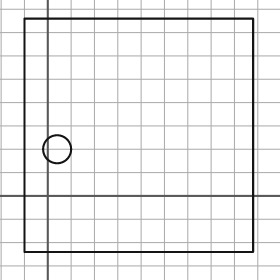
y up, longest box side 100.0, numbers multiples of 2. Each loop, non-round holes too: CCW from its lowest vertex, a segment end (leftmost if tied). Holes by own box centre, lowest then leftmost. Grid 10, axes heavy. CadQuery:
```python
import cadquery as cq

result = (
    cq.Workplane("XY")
    .moveTo(-10.0, -24.0)
    .lineTo(88.0, -24.0)
    .lineTo(88.0, 76.0)
    .lineTo(-10.0, 76.0)
    .close()
    .moveTo(4.0, 20.0)
    .circle(6.0)
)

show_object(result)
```